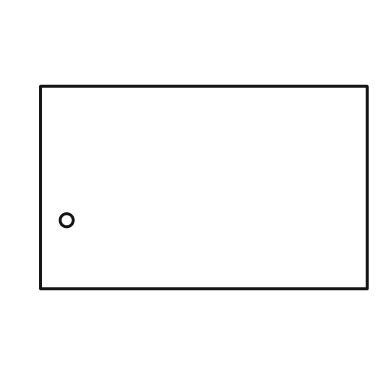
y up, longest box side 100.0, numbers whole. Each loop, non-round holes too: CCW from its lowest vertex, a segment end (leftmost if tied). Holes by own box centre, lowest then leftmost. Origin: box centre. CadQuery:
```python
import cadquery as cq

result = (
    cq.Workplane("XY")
    .moveTo(-50.0, -31.0)
    .lineTo(50.0, -31.0)
    .lineTo(50.0, 31.0)
    .lineTo(-50.0, 31.0)
    .close()
    .moveTo(-42.0, -10.0)
    .circle(2.0)
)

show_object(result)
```